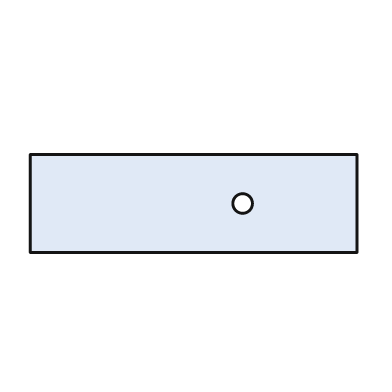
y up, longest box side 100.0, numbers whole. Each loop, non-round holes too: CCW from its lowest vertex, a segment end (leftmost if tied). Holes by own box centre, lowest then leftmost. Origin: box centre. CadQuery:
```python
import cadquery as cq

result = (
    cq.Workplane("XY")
    .moveTo(-50.0, -15.0)
    .lineTo(50.0, -15.0)
    .lineTo(50.0, 15.0)
    .lineTo(-50.0, 15.0)
    .close()
    .moveTo(15.0, 0.0)
    .circle(3.0)
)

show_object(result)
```